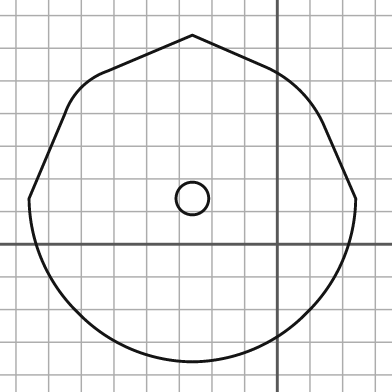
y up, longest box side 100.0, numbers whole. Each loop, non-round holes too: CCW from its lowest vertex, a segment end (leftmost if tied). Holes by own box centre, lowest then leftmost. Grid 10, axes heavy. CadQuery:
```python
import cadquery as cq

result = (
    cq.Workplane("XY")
    .moveTo(-26.0, -36.0)
    .threePointArc((-7.0, -32.0), (9.0, -21.0))
    .threePointArc((20.0, -5.0), (24.0, 14.0))
    .lineTo(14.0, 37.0)
    .threePointArc((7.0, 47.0), (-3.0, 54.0))
    .lineTo(-26.0, 64.0)
    .lineTo(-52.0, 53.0)
    .threePointArc((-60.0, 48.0), (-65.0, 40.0))
    .lineTo(-76.0, 14.0)
    .threePointArc((-72.0, -5.0), (-61.0, -21.0))
    .threePointArc((-45.0, -32.0), (-26.0, -36.0))
    .close()
    .moveTo(-26.0, 14.0)
    .circle(5.0)
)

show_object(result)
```